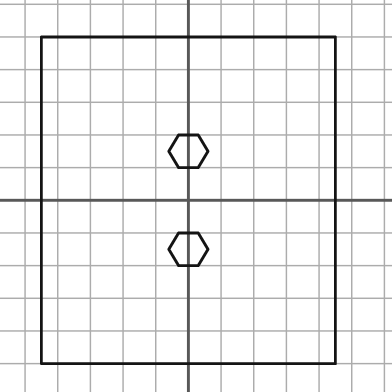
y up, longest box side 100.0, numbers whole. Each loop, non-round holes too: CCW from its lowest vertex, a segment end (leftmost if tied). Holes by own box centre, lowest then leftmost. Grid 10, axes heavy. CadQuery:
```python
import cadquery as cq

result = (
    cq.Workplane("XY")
    .moveTo(-45.0, -50.0)
    .lineTo(45.0, -50.0)
    .lineTo(45.0, 50.0)
    .lineTo(-45.0, 50.0)
    .close()
    .moveTo(-3.0, -20.0)
    .lineTo(3.0, -20.0)
    .lineTo(6.0, -15.0)
    .lineTo(3.0, -10.0)
    .lineTo(-3.0, -10.0)
    .lineTo(-6.0, -15.0)
    .close()
    .moveTo(-3.0, 10.0)
    .lineTo(3.0, 10.0)
    .lineTo(6.0, 15.0)
    .lineTo(3.0, 20.0)
    .lineTo(-3.0, 20.0)
    .lineTo(-6.0, 15.0)
    .close()
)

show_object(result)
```